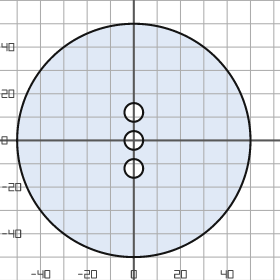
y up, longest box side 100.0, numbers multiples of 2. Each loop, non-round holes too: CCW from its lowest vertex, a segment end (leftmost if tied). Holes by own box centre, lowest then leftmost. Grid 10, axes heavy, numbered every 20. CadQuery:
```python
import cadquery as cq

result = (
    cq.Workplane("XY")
    .moveTo(0.0, 0.0)
    .circle(50.0)
    .moveTo(0.0, -12.0)
    .circle(4.0)
    .moveTo(0.0, 0.0)
    .circle(4.0)
    .moveTo(0.0, 12.0)
    .circle(4.0)
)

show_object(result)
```